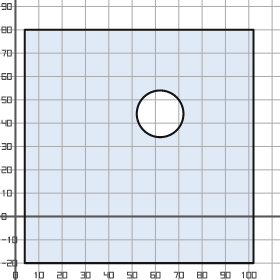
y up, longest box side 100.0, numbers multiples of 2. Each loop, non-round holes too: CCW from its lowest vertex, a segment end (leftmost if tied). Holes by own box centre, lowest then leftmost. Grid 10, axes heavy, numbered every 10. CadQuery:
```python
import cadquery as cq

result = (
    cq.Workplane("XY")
    .moveTo(4.0, -20.0)
    .lineTo(102.0, -20.0)
    .lineTo(102.0, 80.0)
    .lineTo(4.0, 80.0)
    .close()
    .moveTo(62.0, 44.0)
    .circle(10.0)
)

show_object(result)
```